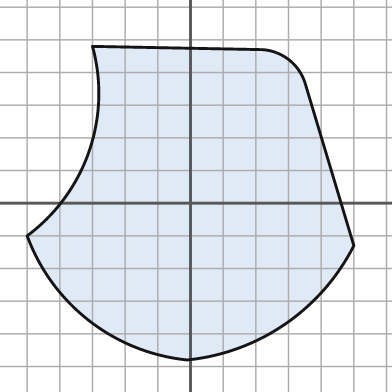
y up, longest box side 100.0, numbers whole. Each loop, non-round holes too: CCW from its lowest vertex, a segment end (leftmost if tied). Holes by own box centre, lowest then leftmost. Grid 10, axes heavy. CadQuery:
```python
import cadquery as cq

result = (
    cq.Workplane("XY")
    .moveTo(-1.0, -48.0)
    .threePointArc((29.0, -37.0), (50.0, -13.0))
    .lineTo(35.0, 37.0)
    .threePointArc((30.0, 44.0), (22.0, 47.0))
    .lineTo(-30.0, 48.0)
    .threePointArc((-31.0, 16.0), (-50.0, -10.0))
    .threePointArc((-31.0, -36.0), (-1.0, -48.0))
    .close()
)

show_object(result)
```